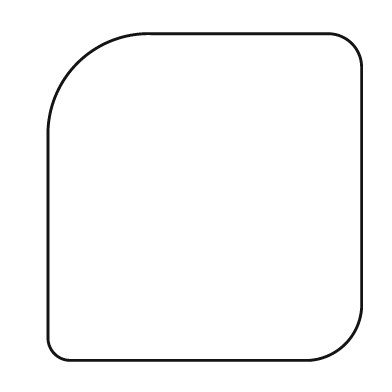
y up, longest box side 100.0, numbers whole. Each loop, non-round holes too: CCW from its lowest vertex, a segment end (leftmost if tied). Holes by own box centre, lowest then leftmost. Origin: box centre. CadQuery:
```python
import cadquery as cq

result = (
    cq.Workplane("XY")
    .moveTo(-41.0, -50.0)
    .lineTo(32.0, -50.0)
    .threePointArc((43.0, -45.0), (48.0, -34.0))
    .lineTo(48.0, 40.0)
    .threePointArc((45.0, 47.0), (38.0, 50.0))
    .lineTo(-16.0, 50.0)
    .threePointArc((-39.0, 41.0), (-48.0, 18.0))
    .lineTo(-48.0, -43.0)
    .threePointArc((-46.0, -48.0), (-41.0, -50.0))
    .close()
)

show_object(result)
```